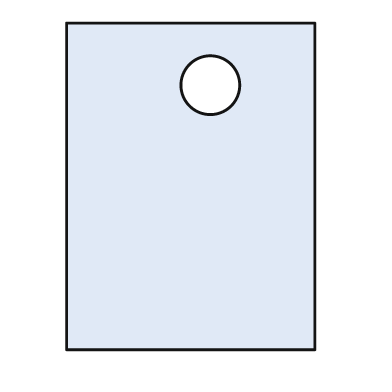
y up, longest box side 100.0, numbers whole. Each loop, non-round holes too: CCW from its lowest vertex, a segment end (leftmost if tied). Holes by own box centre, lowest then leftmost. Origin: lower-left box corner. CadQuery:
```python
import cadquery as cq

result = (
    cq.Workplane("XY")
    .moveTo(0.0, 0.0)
    .lineTo(76.0, 0.0)
    .lineTo(76.0, 100.0)
    .lineTo(0.0, 100.0)
    .close()
    .moveTo(44.0, 81.0)
    .circle(9.0)
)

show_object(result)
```